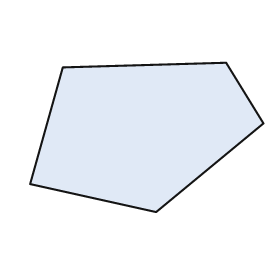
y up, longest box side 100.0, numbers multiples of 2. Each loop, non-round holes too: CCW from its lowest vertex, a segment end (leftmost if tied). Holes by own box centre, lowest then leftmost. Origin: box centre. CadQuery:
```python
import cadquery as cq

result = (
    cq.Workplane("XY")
    .moveTo(4.0, -32.0)
    .lineTo(50.0, 6.0)
    .lineTo(34.0, 32.0)
    .lineTo(-36.0, 30.0)
    .lineTo(-50.0, -20.0)
    .close()
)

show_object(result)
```